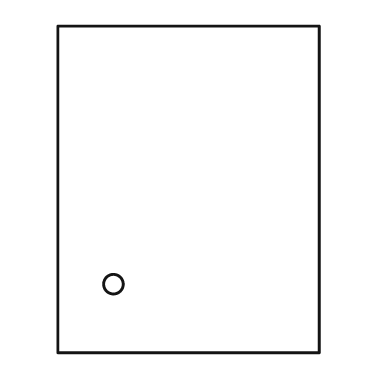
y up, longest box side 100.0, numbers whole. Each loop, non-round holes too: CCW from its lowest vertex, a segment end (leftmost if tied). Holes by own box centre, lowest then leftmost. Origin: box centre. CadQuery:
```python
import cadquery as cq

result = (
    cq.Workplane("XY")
    .moveTo(-40.0, -50.0)
    .lineTo(40.0, -50.0)
    .lineTo(40.0, 50.0)
    .lineTo(-40.0, 50.0)
    .close()
    .moveTo(-23.0, -29.0)
    .circle(3.0)
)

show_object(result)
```